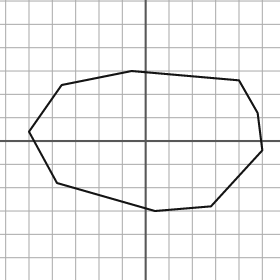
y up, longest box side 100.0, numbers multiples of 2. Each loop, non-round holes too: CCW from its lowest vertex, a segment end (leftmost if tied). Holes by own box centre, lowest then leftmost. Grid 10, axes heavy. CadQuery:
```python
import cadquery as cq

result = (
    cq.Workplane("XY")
    .moveTo(4.0, -30.0)
    .lineTo(28.0, -28.0)
    .lineTo(50.0, -4.0)
    .lineTo(48.0, 12.0)
    .lineTo(40.0, 26.0)
    .lineTo(-6.0, 30.0)
    .lineTo(-36.0, 24.0)
    .lineTo(-50.0, 4.0)
    .lineTo(-38.0, -18.0)
    .close()
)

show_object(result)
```